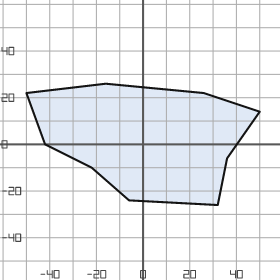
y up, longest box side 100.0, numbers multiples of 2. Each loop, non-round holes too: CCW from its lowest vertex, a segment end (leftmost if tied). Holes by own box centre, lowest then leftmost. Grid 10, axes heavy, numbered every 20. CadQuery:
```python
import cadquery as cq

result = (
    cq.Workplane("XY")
    .moveTo(32.0, -26.0)
    .lineTo(36.0, -6.0)
    .lineTo(50.0, 14.0)
    .lineTo(26.0, 22.0)
    .lineTo(-16.0, 26.0)
    .lineTo(-50.0, 22.0)
    .lineTo(-42.0, 0.0)
    .lineTo(-22.0, -10.0)
    .lineTo(-6.0, -24.0)
    .close()
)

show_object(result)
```